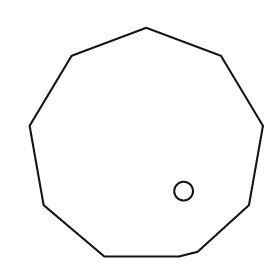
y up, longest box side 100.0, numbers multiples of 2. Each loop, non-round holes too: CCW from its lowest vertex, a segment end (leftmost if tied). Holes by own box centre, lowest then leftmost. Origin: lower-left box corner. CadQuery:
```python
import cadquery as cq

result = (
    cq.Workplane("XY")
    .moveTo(32.0, 0.0)
    .lineTo(64.0, 0.0)
    .lineTo(72.0, 2.0)
    .lineTo(94.0, 22.0)
    .lineTo(100.0, 56.0)
    .lineTo(82.0, 86.0)
    .lineTo(50.0, 98.0)
    .lineTo(18.0, 86.0)
    .lineTo(0.0, 56.0)
    .lineTo(6.0, 22.0)
    .close()
    .moveTo(66.0, 28.0)
    .circle(4.0)
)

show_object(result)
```